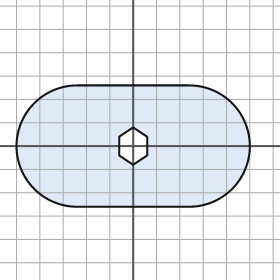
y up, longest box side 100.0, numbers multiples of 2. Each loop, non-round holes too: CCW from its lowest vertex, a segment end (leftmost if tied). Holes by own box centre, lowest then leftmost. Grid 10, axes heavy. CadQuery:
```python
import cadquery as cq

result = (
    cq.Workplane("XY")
    .moveTo(-24.0, -26.0)
    .lineTo(24.0, -26.0)
    .threePointArc((50.0, 0.0), (24.0, 26.0))
    .lineTo(-24.0, 26.0)
    .threePointArc((-50.0, 0.0), (-24.0, -26.0))
    .close()
    .moveTo(0.0, -8.0)
    .lineTo(6.0, -4.0)
    .lineTo(6.0, 4.0)
    .lineTo(0.0, 8.0)
    .lineTo(-6.0, 4.0)
    .lineTo(-6.0, -4.0)
    .close()
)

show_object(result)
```